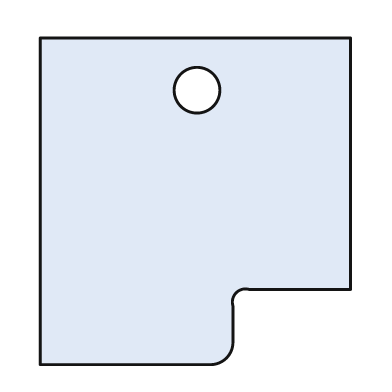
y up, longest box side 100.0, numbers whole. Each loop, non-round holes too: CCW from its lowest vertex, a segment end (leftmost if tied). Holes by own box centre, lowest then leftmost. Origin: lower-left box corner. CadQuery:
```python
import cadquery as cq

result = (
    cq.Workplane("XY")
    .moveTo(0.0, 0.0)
    .lineTo(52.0, 0.0)
    .threePointArc((57.0, 2.0), (59.0, 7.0))
    .lineTo(59.0, 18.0)
    .threePointArc((60.0, 22.0), (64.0, 23.0))
    .lineTo(95.0, 23.0)
    .lineTo(95.0, 100.0)
    .lineTo(0.0, 100.0)
    .close()
    .moveTo(48.0, 84.0)
    .circle(7.0)
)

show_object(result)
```